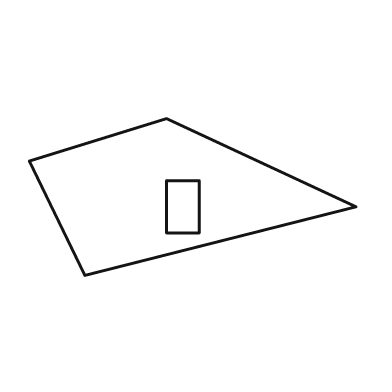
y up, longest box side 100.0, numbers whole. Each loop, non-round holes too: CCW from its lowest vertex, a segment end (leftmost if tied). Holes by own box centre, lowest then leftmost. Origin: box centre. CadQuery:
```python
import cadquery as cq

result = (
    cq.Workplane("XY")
    .moveTo(-33.0, -24.0)
    .lineTo(50.0, -3.0)
    .lineTo(-8.0, 24.0)
    .lineTo(-50.0, 11.0)
    .close()
    .moveTo(-8.0, -11.0)
    .lineTo(2.0, -11.0)
    .lineTo(2.0, 5.0)
    .lineTo(-8.0, 5.0)
    .close()
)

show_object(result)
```